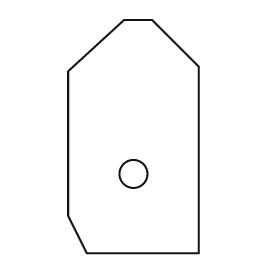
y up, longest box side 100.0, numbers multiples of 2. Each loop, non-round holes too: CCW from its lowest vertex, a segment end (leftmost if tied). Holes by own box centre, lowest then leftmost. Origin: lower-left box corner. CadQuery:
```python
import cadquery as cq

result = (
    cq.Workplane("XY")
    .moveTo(8.0, 0.0)
    .lineTo(56.0, 0.0)
    .lineTo(56.0, 80.0)
    .lineTo(36.0, 100.0)
    .lineTo(24.0, 100.0)
    .lineTo(0.0, 78.0)
    .lineTo(0.0, 16.0)
    .close()
    .moveTo(28.0, 34.0)
    .circle(6.0)
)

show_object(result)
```